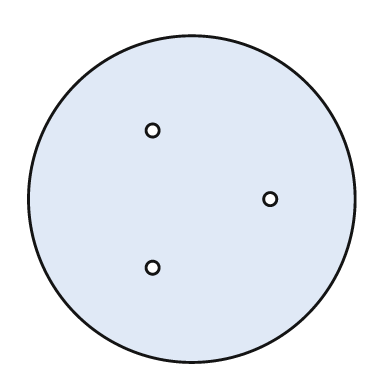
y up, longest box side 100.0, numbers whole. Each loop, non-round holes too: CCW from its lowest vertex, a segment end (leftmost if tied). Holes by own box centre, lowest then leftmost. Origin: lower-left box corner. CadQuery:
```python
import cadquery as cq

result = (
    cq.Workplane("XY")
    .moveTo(50.0, 50.0)
    .circle(50.0)
    .moveTo(38.0, 29.0)
    .circle(2.0)
    .moveTo(74.0, 50.0)
    .circle(2.0)
    .moveTo(38.0, 71.0)
    .circle(2.0)
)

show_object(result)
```